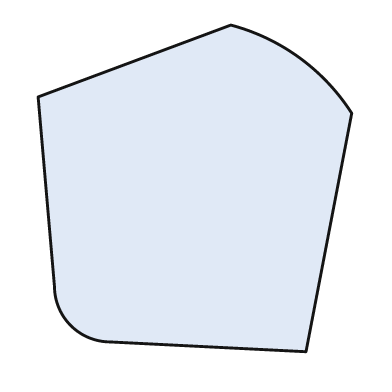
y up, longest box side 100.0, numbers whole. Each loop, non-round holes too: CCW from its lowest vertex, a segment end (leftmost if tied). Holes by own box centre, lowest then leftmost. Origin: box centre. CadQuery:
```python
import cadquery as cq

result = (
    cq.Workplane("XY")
    .moveTo(34.0, -50.0)
    .lineTo(48.0, 23.0)
    .threePointArc((32.0, 40.0), (11.0, 50.0))
    .lineTo(-48.0, 28.0)
    .lineTo(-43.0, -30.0)
    .threePointArc((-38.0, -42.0), (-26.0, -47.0))
    .close()
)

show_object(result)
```